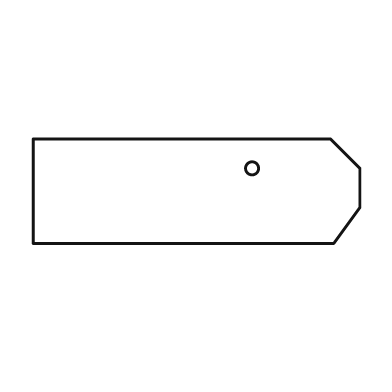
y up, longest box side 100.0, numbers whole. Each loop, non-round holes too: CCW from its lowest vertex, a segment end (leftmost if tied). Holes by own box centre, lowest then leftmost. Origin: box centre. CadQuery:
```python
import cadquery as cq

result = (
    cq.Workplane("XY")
    .moveTo(-50.0, -16.0)
    .lineTo(42.0, -16.0)
    .lineTo(50.0, -5.0)
    .lineTo(50.0, 7.0)
    .lineTo(41.0, 16.0)
    .lineTo(-50.0, 16.0)
    .close()
    .moveTo(17.0, 7.0)
    .circle(2.0)
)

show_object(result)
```